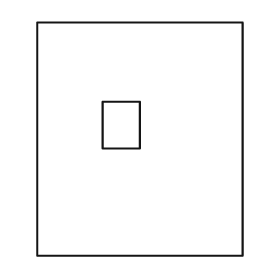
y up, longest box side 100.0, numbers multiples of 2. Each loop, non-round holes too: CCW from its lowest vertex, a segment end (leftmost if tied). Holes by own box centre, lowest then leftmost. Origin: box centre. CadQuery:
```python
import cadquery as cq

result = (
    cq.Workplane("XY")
    .moveTo(-44.0, -50.0)
    .lineTo(44.0, -50.0)
    .lineTo(44.0, 50.0)
    .lineTo(-44.0, 50.0)
    .close()
    .moveTo(-16.0, -4.0)
    .lineTo(0.0, -4.0)
    .lineTo(0.0, 16.0)
    .lineTo(-16.0, 16.0)
    .close()
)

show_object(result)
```